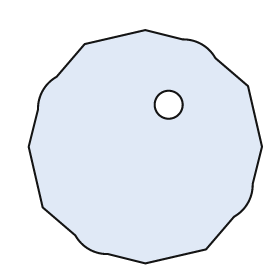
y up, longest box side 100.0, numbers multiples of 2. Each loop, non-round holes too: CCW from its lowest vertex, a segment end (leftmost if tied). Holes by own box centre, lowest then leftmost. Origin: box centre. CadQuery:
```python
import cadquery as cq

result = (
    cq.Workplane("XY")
    .moveTo(0.0, -50.0)
    .lineTo(26.0, -44.0)
    .lineTo(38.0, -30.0)
    .threePointArc((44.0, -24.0), (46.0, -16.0))
    .lineTo(50.0, 0.0)
    .lineTo(44.0, 26.0)
    .lineTo(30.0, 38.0)
    .threePointArc((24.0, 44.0), (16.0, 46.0))
    .lineTo(0.0, 50.0)
    .lineTo(-26.0, 44.0)
    .lineTo(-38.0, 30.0)
    .threePointArc((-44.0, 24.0), (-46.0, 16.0))
    .lineTo(-50.0, 0.0)
    .lineTo(-44.0, -26.0)
    .lineTo(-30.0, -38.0)
    .threePointArc((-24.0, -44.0), (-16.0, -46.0))
    .close()
    .moveTo(10.0, 18.0)
    .circle(6.0)
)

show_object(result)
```